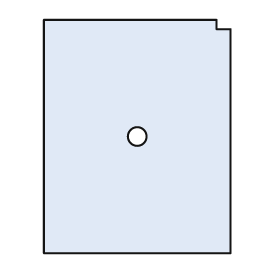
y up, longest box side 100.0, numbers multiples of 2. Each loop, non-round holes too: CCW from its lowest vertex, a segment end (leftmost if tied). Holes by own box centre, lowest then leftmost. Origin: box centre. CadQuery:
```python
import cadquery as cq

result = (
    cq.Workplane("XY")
    .moveTo(-40.0, -50.0)
    .lineTo(40.0, -50.0)
    .lineTo(40.0, 46.0)
    .lineTo(34.0, 46.0)
    .lineTo(34.0, 50.0)
    .lineTo(-40.0, 50.0)
    .close()
    .moveTo(0.0, 0.0)
    .circle(4.0)
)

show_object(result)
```